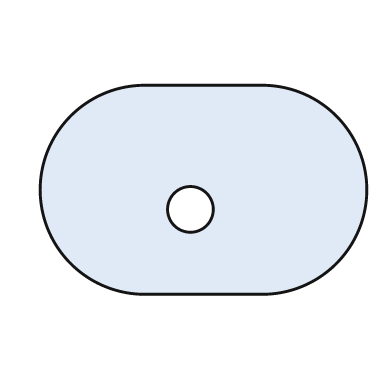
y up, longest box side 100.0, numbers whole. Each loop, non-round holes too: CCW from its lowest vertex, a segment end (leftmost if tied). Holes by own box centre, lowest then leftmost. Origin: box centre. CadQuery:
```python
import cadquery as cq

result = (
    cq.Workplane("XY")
    .moveTo(-18.0, -32.0)
    .lineTo(18.0, -32.0)
    .threePointArc((50.0, 0.0), (18.0, 32.0))
    .lineTo(-18.0, 32.0)
    .threePointArc((-50.0, 0.0), (-18.0, -32.0))
    .close()
    .moveTo(-4.0, -6.0)
    .circle(7.0)
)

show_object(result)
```